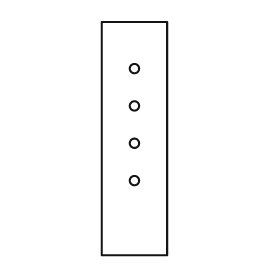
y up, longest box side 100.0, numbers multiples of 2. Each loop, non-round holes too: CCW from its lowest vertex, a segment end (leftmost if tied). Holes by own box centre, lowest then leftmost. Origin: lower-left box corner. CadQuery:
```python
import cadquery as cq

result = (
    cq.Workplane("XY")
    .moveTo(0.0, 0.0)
    .lineTo(28.0, 0.0)
    .lineTo(28.0, 100.0)
    .lineTo(0.0, 100.0)
    .close()
    .moveTo(14.0, 32.0)
    .circle(2.0)
    .moveTo(14.0, 48.0)
    .circle(2.0)
    .moveTo(14.0, 64.0)
    .circle(2.0)
    .moveTo(14.0, 80.0)
    .circle(2.0)
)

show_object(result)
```